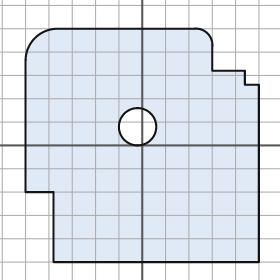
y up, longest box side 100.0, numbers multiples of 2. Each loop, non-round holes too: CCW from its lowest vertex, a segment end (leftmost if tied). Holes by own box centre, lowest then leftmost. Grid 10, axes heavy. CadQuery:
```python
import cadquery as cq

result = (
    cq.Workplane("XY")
    .moveTo(-38.0, -50.0)
    .lineTo(50.0, -50.0)
    .lineTo(50.0, 26.0)
    .lineTo(44.0, 26.0)
    .lineTo(44.0, 32.0)
    .lineTo(30.0, 32.0)
    .lineTo(30.0, 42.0)
    .threePointArc((28.0, 48.0), (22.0, 50.0))
    .lineTo(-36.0, 50.0)
    .threePointArc((-46.0, 46.0), (-50.0, 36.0))
    .lineTo(-50.0, -20.0)
    .lineTo(-38.0, -20.0)
    .close()
    .moveTo(-2.0, 8.0)
    .circle(8.0)
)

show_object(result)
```